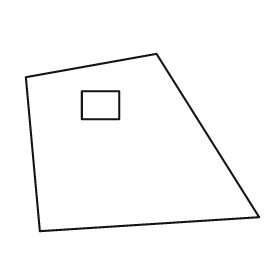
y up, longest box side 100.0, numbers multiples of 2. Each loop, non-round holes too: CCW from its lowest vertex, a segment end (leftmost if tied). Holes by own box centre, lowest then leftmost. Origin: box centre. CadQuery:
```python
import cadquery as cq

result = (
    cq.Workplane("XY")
    .moveTo(-44.0, -38.0)
    .lineTo(50.0, -32.0)
    .lineTo(6.0, 38.0)
    .lineTo(-50.0, 28.0)
    .close()
    .moveTo(-26.0, 10.0)
    .lineTo(-10.0, 10.0)
    .lineTo(-10.0, 22.0)
    .lineTo(-26.0, 22.0)
    .close()
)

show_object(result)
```